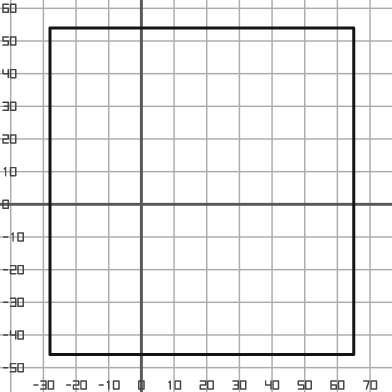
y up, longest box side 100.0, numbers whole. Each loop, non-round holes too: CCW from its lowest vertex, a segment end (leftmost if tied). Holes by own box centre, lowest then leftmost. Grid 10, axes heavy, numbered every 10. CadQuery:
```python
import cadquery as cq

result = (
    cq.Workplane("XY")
    .moveTo(-28.0, -46.0)
    .lineTo(65.0, -46.0)
    .lineTo(65.0, 54.0)
    .lineTo(-28.0, 54.0)
    .close()
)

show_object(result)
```